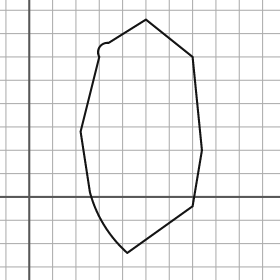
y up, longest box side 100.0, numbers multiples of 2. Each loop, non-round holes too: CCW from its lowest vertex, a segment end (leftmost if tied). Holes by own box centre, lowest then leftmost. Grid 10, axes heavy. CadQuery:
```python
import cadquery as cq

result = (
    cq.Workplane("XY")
    .moveTo(42.0, -24.0)
    .lineTo(70.0, -4.0)
    .lineTo(74.0, 20.0)
    .lineTo(70.0, 60.0)
    .lineTo(50.0, 76.0)
    .lineTo(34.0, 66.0)
    .threePointArc((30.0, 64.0), (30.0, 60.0))
    .lineTo(22.0, 28.0)
    .lineTo(26.0, 2.0)
    .threePointArc((32.0, -12.0), (42.0, -24.0))
    .close()
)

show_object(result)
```